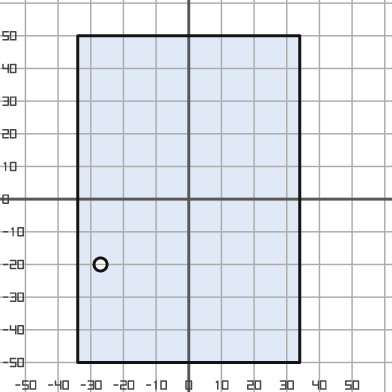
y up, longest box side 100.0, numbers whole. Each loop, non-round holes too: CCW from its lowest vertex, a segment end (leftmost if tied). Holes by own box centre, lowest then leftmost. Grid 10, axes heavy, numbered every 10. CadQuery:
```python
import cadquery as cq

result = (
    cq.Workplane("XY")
    .moveTo(-34.0, -50.0)
    .lineTo(34.0, -50.0)
    .lineTo(34.0, 50.0)
    .lineTo(-34.0, 50.0)
    .close()
    .moveTo(-27.0, -20.0)
    .circle(2.0)
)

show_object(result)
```